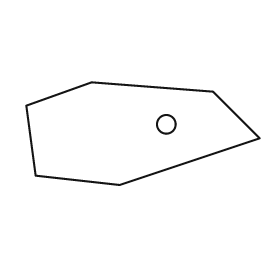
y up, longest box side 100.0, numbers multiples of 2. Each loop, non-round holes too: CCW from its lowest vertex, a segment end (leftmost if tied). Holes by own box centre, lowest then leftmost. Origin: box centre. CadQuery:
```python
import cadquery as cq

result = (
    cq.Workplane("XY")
    .moveTo(-10.0, -22.0)
    .lineTo(50.0, -2.0)
    .lineTo(30.0, 18.0)
    .lineTo(-22.0, 22.0)
    .lineTo(-50.0, 12.0)
    .lineTo(-46.0, -18.0)
    .close()
    .moveTo(10.0, 4.0)
    .circle(4.0)
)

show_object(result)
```